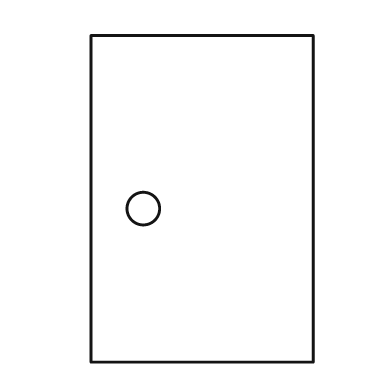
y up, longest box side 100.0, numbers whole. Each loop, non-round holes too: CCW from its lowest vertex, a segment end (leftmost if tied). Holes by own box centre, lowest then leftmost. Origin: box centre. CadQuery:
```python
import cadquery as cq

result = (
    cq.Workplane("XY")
    .moveTo(-34.0, -50.0)
    .lineTo(34.0, -50.0)
    .lineTo(34.0, 50.0)
    .lineTo(-34.0, 50.0)
    .close()
    .moveTo(-18.0, -3.0)
    .circle(5.0)
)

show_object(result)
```